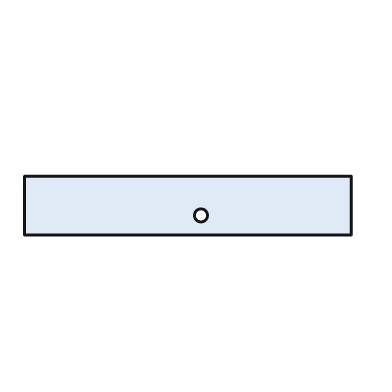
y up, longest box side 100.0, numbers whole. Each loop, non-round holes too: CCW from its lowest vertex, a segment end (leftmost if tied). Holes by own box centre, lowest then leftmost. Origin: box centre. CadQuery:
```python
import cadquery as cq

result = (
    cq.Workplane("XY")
    .moveTo(-50.0, -9.0)
    .lineTo(50.0, -9.0)
    .lineTo(50.0, 9.0)
    .lineTo(-50.0, 9.0)
    .close()
    .moveTo(4.0, -3.0)
    .circle(2.0)
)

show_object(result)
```